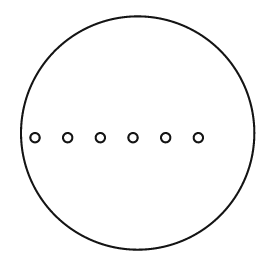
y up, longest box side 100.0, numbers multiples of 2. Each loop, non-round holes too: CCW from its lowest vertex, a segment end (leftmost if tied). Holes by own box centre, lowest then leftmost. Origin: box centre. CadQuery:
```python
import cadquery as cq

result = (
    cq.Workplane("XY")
    .moveTo(0.0, 0.0)
    .circle(50.0)
    .moveTo(-44.0, -2.0)
    .circle(2.0)
    .moveTo(-30.0, -2.0)
    .circle(2.0)
    .moveTo(-16.0, -2.0)
    .circle(2.0)
    .moveTo(-2.0, -2.0)
    .circle(2.0)
    .moveTo(12.0, -2.0)
    .circle(2.0)
    .moveTo(26.0, -2.0)
    .circle(2.0)
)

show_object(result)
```